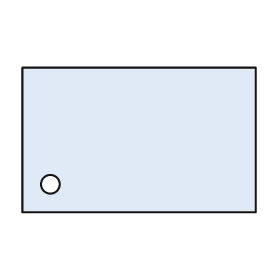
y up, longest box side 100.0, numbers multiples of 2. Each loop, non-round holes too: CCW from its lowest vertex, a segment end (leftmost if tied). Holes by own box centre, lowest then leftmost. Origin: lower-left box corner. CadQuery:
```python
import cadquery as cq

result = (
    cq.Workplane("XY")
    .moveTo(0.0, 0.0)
    .lineTo(100.0, 0.0)
    .lineTo(100.0, 62.0)
    .lineTo(0.0, 62.0)
    .close()
    .moveTo(12.0, 12.0)
    .circle(4.0)
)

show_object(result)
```